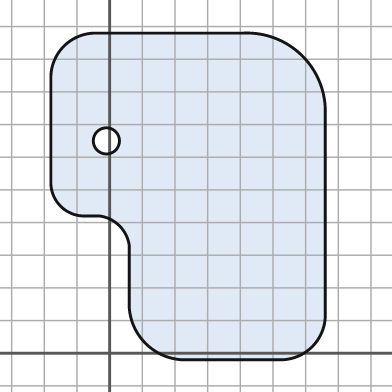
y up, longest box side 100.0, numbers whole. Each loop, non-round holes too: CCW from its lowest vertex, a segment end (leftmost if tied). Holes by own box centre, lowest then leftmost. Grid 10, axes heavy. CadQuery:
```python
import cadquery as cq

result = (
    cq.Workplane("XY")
    .moveTo(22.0, -2.0)
    .lineTo(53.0, -2.0)
    .threePointArc((62.0, 2.0), (66.0, 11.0))
    .lineTo(66.0, 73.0)
    .threePointArc((59.0, 91.0), (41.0, 98.0))
    .lineTo(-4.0, 98.0)
    .threePointArc((-14.0, 94.0), (-18.0, 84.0))
    .lineTo(-18.0, 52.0)
    .threePointArc((-15.0, 45.0), (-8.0, 42.0))
    .lineTo(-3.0, 42.0)
    .threePointArc((3.0, 39.0), (6.0, 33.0))
    .lineTo(6.0, 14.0)
    .threePointArc((11.0, 3.0), (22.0, -2.0))
    .close()
    .moveTo(-1.0, 65.0)
    .circle(4.0)
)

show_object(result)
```